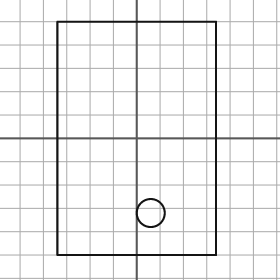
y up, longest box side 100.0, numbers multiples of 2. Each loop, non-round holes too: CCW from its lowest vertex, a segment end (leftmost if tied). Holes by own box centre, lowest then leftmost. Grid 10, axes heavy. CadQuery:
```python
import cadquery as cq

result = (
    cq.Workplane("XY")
    .moveTo(-34.0, -50.0)
    .lineTo(34.0, -50.0)
    .lineTo(34.0, 50.0)
    .lineTo(-34.0, 50.0)
    .close()
    .moveTo(6.0, -32.0)
    .circle(6.0)
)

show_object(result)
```